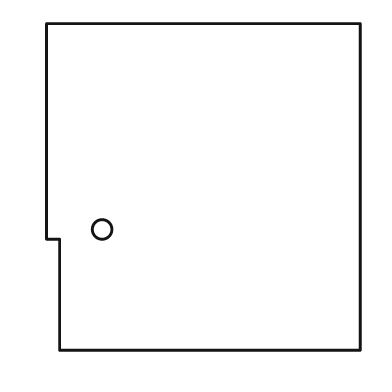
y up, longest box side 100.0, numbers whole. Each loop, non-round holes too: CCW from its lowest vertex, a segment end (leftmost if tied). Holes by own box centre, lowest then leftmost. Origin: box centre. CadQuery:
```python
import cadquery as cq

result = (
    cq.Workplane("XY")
    .moveTo(-44.0, -50.0)
    .lineTo(48.0, -50.0)
    .lineTo(48.0, 50.0)
    .lineTo(-48.0, 50.0)
    .lineTo(-48.0, -16.0)
    .lineTo(-44.0, -16.0)
    .close()
    .moveTo(-31.0, -13.0)
    .circle(3.0)
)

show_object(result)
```